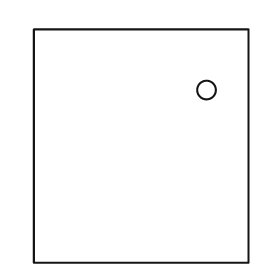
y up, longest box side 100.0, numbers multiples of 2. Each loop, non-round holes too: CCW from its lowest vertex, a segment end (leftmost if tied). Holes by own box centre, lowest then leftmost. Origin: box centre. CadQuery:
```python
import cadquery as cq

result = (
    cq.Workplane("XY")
    .moveTo(-46.0, -50.0)
    .lineTo(46.0, -50.0)
    .lineTo(46.0, 50.0)
    .lineTo(-46.0, 50.0)
    .close()
    .moveTo(28.0, 24.0)
    .circle(4.0)
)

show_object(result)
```